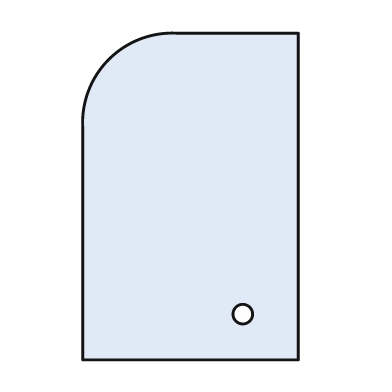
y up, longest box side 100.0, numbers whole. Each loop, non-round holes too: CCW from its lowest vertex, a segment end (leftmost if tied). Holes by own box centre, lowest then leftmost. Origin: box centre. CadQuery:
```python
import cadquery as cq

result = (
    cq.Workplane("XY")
    .moveTo(-33.0, -50.0)
    .lineTo(33.0, -50.0)
    .lineTo(33.0, 50.0)
    .lineTo(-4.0, 50.0)
    .threePointArc((-25.0, 42.0), (-33.0, 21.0))
    .close()
    .moveTo(16.0, -36.0)
    .circle(3.0)
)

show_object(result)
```